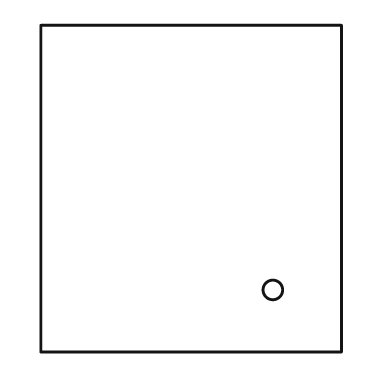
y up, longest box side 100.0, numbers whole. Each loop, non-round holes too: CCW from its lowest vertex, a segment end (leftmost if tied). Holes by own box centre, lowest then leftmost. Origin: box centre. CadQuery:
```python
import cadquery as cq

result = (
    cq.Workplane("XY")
    .moveTo(-46.0, -50.0)
    .lineTo(46.0, -50.0)
    .lineTo(46.0, 50.0)
    .lineTo(-46.0, 50.0)
    .close()
    .moveTo(25.0, -31.0)
    .circle(3.0)
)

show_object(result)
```